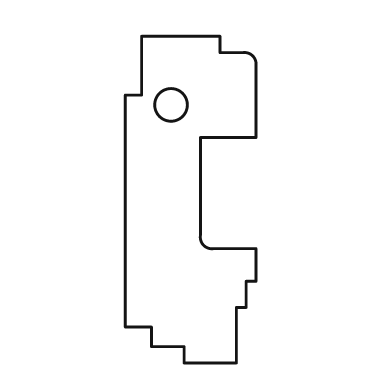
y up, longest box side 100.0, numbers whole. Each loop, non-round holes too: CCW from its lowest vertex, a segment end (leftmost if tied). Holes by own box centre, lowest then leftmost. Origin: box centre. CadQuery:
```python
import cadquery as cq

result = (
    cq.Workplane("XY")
    .moveTo(-2.0, -50.0)
    .lineTo(14.0, -50.0)
    .lineTo(14.0, -33.0)
    .lineTo(17.0, -33.0)
    .lineTo(17.0, -25.0)
    .lineTo(20.0, -25.0)
    .lineTo(20.0, -15.0)
    .lineTo(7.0, -15.0)
    .threePointArc((4.0, -14.0), (3.0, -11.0))
    .lineTo(3.0, 19.0)
    .lineTo(20.0, 19.0)
    .lineTo(20.0, 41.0)
    .threePointArc((19.0, 44.0), (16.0, 45.0))
    .lineTo(9.0, 45.0)
    .lineTo(9.0, 50.0)
    .lineTo(-15.0, 50.0)
    .lineTo(-15.0, 32.0)
    .lineTo(-20.0, 32.0)
    .lineTo(-20.0, -39.0)
    .lineTo(-12.0, -39.0)
    .lineTo(-12.0, -45.0)
    .lineTo(-2.0, -45.0)
    .close()
    .moveTo(-6.0, 29.0)
    .circle(5.0)
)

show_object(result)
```